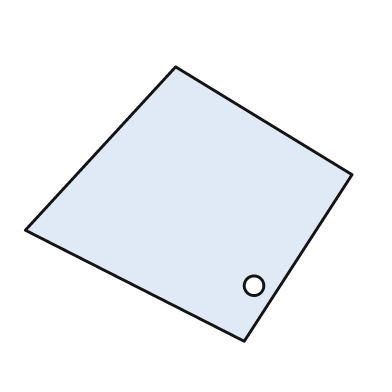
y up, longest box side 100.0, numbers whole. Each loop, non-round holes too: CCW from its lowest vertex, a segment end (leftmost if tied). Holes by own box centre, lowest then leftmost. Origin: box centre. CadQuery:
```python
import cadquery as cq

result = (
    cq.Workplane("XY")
    .moveTo(17.0, -42.0)
    .lineTo(50.0, 9.0)
    .lineTo(-4.0, 42.0)
    .lineTo(-50.0, -8.0)
    .close()
    .moveTo(20.0, -25.0)
    .circle(3.0)
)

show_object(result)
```